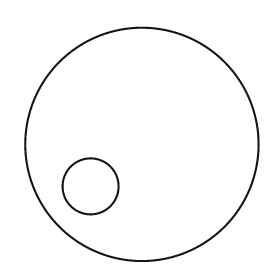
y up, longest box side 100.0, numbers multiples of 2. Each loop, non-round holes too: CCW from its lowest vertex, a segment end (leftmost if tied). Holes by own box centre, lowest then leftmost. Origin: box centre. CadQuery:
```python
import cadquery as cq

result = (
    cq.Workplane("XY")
    .moveTo(0.0, 0.0)
    .circle(50.0)
    .moveTo(-22.0, -18.0)
    .circle(12.0)
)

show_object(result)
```